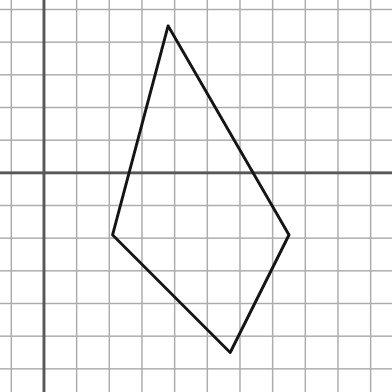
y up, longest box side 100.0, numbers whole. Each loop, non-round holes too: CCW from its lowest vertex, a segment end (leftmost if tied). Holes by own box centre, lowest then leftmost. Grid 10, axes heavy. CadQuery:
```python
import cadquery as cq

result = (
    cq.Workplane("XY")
    .moveTo(57.0, -55.0)
    .lineTo(75.0, -19.0)
    .lineTo(38.0, 45.0)
    .lineTo(21.0, -19.0)
    .close()
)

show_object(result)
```